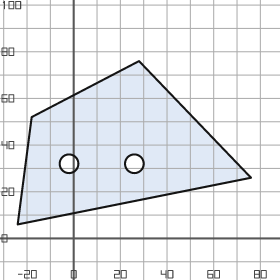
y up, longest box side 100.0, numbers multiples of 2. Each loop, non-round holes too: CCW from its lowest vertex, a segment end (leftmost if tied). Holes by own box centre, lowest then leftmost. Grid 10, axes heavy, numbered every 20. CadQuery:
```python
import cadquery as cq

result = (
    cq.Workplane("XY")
    .moveTo(-24.0, 6.0)
    .lineTo(76.0, 26.0)
    .lineTo(28.0, 76.0)
    .lineTo(-18.0, 52.0)
    .close()
    .moveTo(-2.0, 32.0)
    .circle(4.0)
    .moveTo(26.0, 32.0)
    .circle(4.0)
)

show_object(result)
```